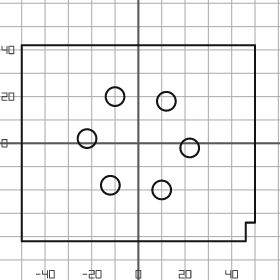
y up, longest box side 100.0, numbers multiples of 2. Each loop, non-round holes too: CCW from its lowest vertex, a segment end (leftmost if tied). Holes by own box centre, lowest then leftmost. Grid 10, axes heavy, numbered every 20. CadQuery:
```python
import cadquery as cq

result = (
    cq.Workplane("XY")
    .moveTo(-50.0, -42.0)
    .lineTo(46.0, -42.0)
    .lineTo(46.0, -34.0)
    .lineTo(50.0, -34.0)
    .lineTo(50.0, 42.0)
    .lineTo(-50.0, 42.0)
    .close()
    .moveTo(10.0, -20.0)
    .circle(4.0)
    .moveTo(-12.0, -18.0)
    .circle(4.0)
    .moveTo(22.0, -2.0)
    .circle(4.0)
    .moveTo(-22.0, 2.0)
    .circle(4.0)
    .moveTo(12.0, 18.0)
    .circle(4.0)
    .moveTo(-10.0, 20.0)
    .circle(4.0)
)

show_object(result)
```